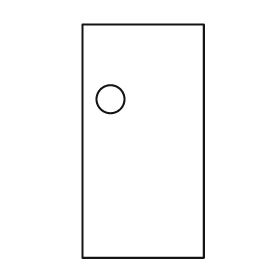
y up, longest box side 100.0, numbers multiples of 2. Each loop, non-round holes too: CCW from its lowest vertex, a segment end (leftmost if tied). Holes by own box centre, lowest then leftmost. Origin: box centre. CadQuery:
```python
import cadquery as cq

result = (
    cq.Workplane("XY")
    .moveTo(-26.0, -50.0)
    .lineTo(26.0, -50.0)
    .lineTo(26.0, 50.0)
    .lineTo(-26.0, 50.0)
    .close()
    .moveTo(-14.0, 18.0)
    .circle(6.0)
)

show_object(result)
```